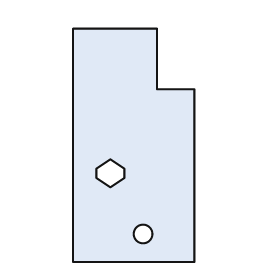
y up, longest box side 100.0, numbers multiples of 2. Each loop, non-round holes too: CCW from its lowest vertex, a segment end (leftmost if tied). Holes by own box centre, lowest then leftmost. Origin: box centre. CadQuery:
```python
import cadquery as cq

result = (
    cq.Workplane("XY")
    .moveTo(-26.0, -50.0)
    .lineTo(26.0, -50.0)
    .lineTo(26.0, 24.0)
    .lineTo(10.0, 24.0)
    .lineTo(10.0, 50.0)
    .lineTo(-26.0, 50.0)
    .close()
    .moveTo(4.0, -38.0)
    .circle(4.0)
    .moveTo(-10.0, -18.0)
    .lineTo(-4.0, -14.0)
    .lineTo(-4.0, -10.0)
    .lineTo(-10.0, -6.0)
    .lineTo(-16.0, -10.0)
    .lineTo(-16.0, -14.0)
    .close()
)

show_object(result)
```